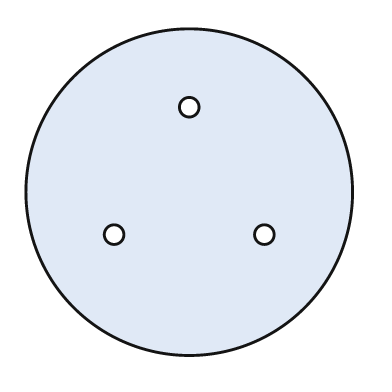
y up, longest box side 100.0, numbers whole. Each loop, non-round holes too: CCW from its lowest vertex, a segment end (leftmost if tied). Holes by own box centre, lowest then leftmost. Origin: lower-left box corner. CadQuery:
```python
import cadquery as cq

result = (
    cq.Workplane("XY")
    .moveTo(50.0, 50.0)
    .circle(50.0)
    .moveTo(27.0, 37.0)
    .circle(3.0)
    .moveTo(73.0, 37.0)
    .circle(3.0)
    .moveTo(50.0, 76.0)
    .circle(3.0)
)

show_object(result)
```